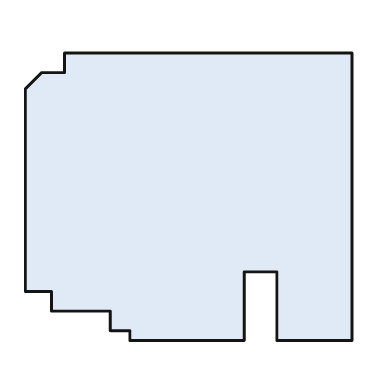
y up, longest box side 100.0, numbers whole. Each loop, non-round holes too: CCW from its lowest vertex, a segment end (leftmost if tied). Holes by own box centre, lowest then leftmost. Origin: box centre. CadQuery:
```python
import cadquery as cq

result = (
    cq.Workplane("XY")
    .moveTo(-18.0, -44.0)
    .lineTo(17.0, -44.0)
    .lineTo(17.0, -23.0)
    .lineTo(27.0, -23.0)
    .lineTo(27.0, -44.0)
    .lineTo(50.0, -44.0)
    .lineTo(50.0, 44.0)
    .lineTo(-38.0, 44.0)
    .lineTo(-38.0, 38.0)
    .lineTo(-45.0, 38.0)
    .lineTo(-50.0, 33.0)
    .lineTo(-50.0, -29.0)
    .lineTo(-42.0, -29.0)
    .lineTo(-42.0, -35.0)
    .lineTo(-24.0, -35.0)
    .lineTo(-24.0, -41.0)
    .lineTo(-18.0, -41.0)
    .close()
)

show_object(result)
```